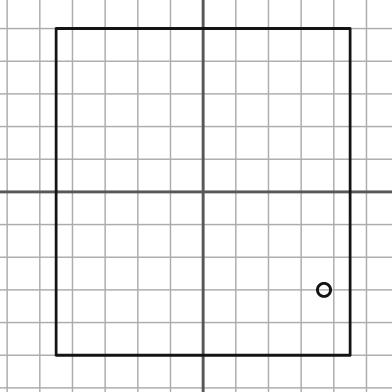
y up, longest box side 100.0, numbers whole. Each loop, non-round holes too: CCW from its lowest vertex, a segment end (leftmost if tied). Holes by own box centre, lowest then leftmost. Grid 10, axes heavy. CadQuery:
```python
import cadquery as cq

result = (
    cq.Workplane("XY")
    .moveTo(-45.0, -50.0)
    .lineTo(45.0, -50.0)
    .lineTo(45.0, 50.0)
    .lineTo(-45.0, 50.0)
    .close()
    .moveTo(37.0, -30.0)
    .circle(2.0)
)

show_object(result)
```